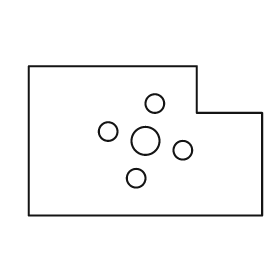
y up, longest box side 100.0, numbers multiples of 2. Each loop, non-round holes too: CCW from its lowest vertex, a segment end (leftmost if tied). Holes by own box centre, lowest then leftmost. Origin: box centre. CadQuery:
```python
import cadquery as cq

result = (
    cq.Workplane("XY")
    .moveTo(-50.0, -32.0)
    .lineTo(50.0, -32.0)
    .lineTo(50.0, 12.0)
    .lineTo(22.0, 12.0)
    .lineTo(22.0, 32.0)
    .lineTo(-50.0, 32.0)
    .close()
    .moveTo(-4.0, -16.0)
    .circle(4.0)
    .moveTo(16.0, -4.0)
    .circle(4.0)
    .moveTo(0.0, 0.0)
    .circle(6.0)
    .moveTo(-16.0, 4.0)
    .circle(4.0)
    .moveTo(4.0, 16.0)
    .circle(4.0)
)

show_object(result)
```